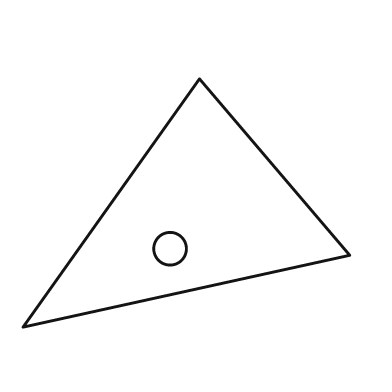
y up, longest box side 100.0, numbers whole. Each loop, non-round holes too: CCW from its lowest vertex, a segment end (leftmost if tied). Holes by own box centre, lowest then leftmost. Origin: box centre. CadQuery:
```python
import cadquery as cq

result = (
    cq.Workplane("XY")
    .moveTo(-50.0, -38.0)
    .lineTo(50.0, -16.0)
    .lineTo(4.0, 38.0)
    .close()
    .moveTo(-5.0, -14.0)
    .circle(5.0)
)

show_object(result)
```